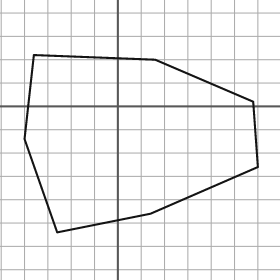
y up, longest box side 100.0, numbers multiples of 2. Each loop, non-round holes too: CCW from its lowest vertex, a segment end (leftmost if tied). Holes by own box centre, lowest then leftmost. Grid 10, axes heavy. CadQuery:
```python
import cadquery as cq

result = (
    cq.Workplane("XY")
    .moveTo(-26.0, -54.0)
    .lineTo(14.0, -46.0)
    .lineTo(60.0, -26.0)
    .lineTo(58.0, 2.0)
    .lineTo(16.0, 20.0)
    .lineTo(-36.0, 22.0)
    .lineTo(-40.0, -14.0)
    .close()
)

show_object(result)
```